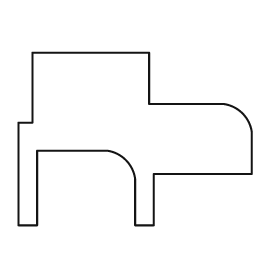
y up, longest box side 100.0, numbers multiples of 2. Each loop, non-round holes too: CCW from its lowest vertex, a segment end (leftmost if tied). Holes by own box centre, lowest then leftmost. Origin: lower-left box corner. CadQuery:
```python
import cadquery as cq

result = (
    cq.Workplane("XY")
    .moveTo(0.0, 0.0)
    .lineTo(8.0, 0.0)
    .lineTo(8.0, 32.0)
    .lineTo(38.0, 32.0)
    .threePointArc((46.0, 28.0), (50.0, 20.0))
    .lineTo(50.0, 0.0)
    .lineTo(58.0, 0.0)
    .lineTo(58.0, 22.0)
    .lineTo(100.0, 22.0)
    .lineTo(100.0, 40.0)
    .threePointArc((96.0, 48.0), (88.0, 52.0))
    .lineTo(56.0, 52.0)
    .lineTo(56.0, 74.0)
    .lineTo(6.0, 74.0)
    .lineTo(6.0, 44.0)
    .lineTo(0.0, 44.0)
    .close()
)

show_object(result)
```